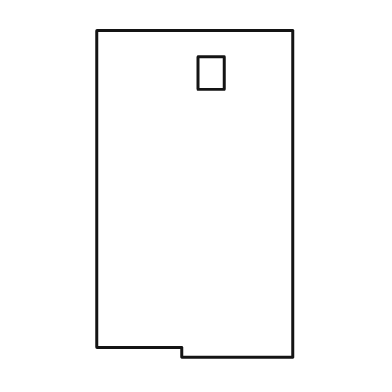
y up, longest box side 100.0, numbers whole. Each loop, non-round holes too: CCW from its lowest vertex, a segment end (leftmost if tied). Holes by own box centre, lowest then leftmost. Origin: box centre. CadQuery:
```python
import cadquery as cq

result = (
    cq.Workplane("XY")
    .moveTo(-4.0, -50.0)
    .lineTo(30.0, -50.0)
    .lineTo(30.0, 50.0)
    .lineTo(-30.0, 50.0)
    .lineTo(-30.0, -47.0)
    .lineTo(-4.0, -47.0)
    .close()
    .moveTo(1.0, 32.0)
    .lineTo(9.0, 32.0)
    .lineTo(9.0, 42.0)
    .lineTo(1.0, 42.0)
    .close()
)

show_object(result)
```